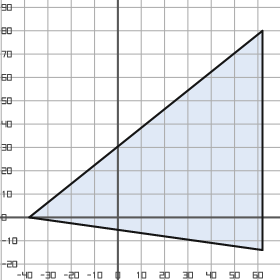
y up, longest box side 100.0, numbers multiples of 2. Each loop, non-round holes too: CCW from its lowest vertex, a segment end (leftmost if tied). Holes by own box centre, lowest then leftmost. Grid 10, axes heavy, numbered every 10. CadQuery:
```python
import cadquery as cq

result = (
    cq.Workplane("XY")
    .moveTo(62.0, -14.0)
    .lineTo(62.0, 80.0)
    .lineTo(-38.0, 0.0)
    .close()
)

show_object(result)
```